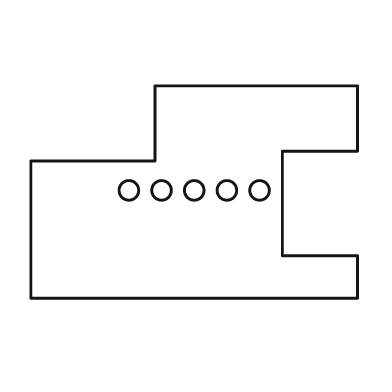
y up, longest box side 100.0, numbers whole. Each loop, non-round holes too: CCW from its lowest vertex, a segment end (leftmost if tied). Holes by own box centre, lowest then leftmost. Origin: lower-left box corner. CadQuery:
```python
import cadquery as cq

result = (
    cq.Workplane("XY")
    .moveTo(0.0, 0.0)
    .lineTo(100.0, 0.0)
    .lineTo(100.0, 13.0)
    .lineTo(77.0, 13.0)
    .lineTo(77.0, 45.0)
    .lineTo(100.0, 45.0)
    .lineTo(100.0, 65.0)
    .lineTo(38.0, 65.0)
    .lineTo(38.0, 42.0)
    .lineTo(0.0, 42.0)
    .close()
    .moveTo(30.0, 33.0)
    .circle(3.0)
    .moveTo(40.0, 33.0)
    .circle(3.0)
    .moveTo(50.0, 33.0)
    .circle(3.0)
    .moveTo(60.0, 33.0)
    .circle(3.0)
    .moveTo(70.0, 33.0)
    .circle(3.0)
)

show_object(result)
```